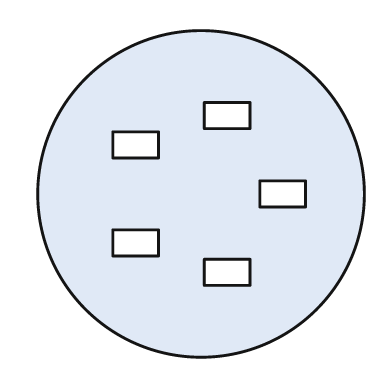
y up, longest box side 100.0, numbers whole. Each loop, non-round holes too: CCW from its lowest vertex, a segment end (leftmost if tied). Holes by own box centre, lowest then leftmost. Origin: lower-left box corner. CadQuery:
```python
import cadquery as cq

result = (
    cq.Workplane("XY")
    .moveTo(50.0, 50.0)
    .circle(50.0)
    .moveTo(51.0, 22.0)
    .lineTo(65.0, 22.0)
    .lineTo(65.0, 30.0)
    .lineTo(51.0, 30.0)
    .close()
    .moveTo(23.0, 31.0)
    .lineTo(37.0, 31.0)
    .lineTo(37.0, 39.0)
    .lineTo(23.0, 39.0)
    .close()
    .moveTo(68.0, 46.0)
    .lineTo(82.0, 46.0)
    .lineTo(82.0, 54.0)
    .lineTo(68.0, 54.0)
    .close()
    .moveTo(23.0, 61.0)
    .lineTo(37.0, 61.0)
    .lineTo(37.0, 69.0)
    .lineTo(23.0, 69.0)
    .close()
    .moveTo(51.0, 70.0)
    .lineTo(65.0, 70.0)
    .lineTo(65.0, 78.0)
    .lineTo(51.0, 78.0)
    .close()
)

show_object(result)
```